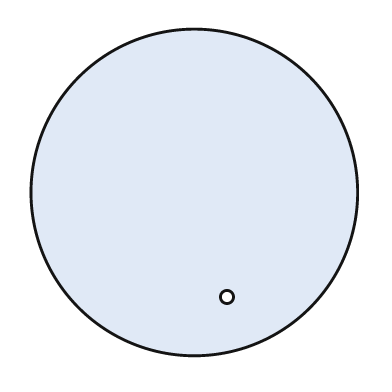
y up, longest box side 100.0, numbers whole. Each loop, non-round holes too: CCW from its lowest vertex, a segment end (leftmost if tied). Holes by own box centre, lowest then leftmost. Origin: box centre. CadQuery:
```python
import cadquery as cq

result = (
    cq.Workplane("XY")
    .moveTo(0.0, 0.0)
    .circle(50.0)
    .moveTo(10.0, -32.0)
    .circle(2.0)
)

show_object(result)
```